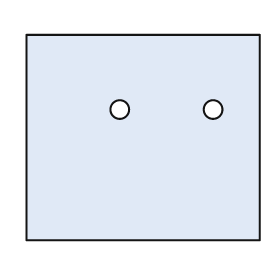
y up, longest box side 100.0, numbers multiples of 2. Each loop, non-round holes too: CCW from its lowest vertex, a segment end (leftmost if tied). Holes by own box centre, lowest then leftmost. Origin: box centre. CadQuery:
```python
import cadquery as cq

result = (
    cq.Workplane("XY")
    .moveTo(-50.0, -44.0)
    .lineTo(50.0, -44.0)
    .lineTo(50.0, 44.0)
    .lineTo(-50.0, 44.0)
    .close()
    .moveTo(-10.0, 12.0)
    .circle(4.0)
    .moveTo(30.0, 12.0)
    .circle(4.0)
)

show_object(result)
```